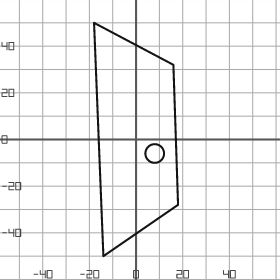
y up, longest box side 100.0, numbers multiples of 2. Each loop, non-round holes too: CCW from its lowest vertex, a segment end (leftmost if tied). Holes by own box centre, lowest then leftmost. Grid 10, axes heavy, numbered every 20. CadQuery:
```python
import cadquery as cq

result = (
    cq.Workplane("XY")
    .moveTo(-14.0, -50.0)
    .lineTo(18.0, -28.0)
    .lineTo(16.0, 32.0)
    .lineTo(-18.0, 50.0)
    .close()
    .moveTo(8.0, -6.0)
    .circle(4.0)
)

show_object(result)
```